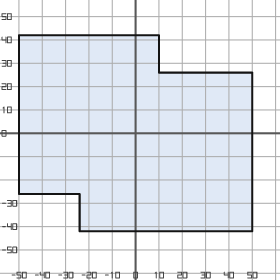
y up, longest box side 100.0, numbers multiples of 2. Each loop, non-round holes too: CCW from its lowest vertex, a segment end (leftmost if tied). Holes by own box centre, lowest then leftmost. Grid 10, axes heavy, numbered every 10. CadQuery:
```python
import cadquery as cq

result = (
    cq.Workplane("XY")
    .moveTo(-24.0, -42.0)
    .lineTo(50.0, -42.0)
    .lineTo(50.0, 26.0)
    .lineTo(10.0, 26.0)
    .lineTo(10.0, 42.0)
    .lineTo(-50.0, 42.0)
    .lineTo(-50.0, -26.0)
    .lineTo(-24.0, -26.0)
    .close()
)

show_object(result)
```